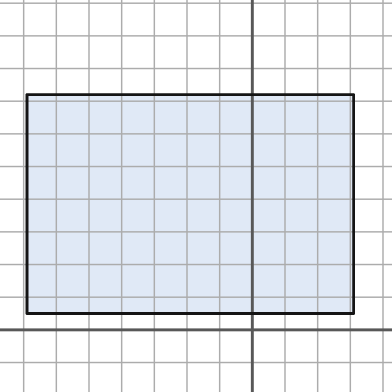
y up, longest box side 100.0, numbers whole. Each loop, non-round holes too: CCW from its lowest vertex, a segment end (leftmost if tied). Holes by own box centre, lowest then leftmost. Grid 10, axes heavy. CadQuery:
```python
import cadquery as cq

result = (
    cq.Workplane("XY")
    .moveTo(-69.0, 5.0)
    .lineTo(31.0, 5.0)
    .lineTo(31.0, 72.0)
    .lineTo(-69.0, 72.0)
    .close()
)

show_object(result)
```